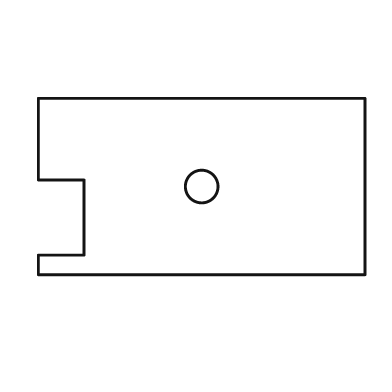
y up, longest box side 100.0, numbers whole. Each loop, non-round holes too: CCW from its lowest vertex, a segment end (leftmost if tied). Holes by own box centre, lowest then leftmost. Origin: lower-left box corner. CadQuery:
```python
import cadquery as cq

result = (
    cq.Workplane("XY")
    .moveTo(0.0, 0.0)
    .lineTo(100.0, 0.0)
    .lineTo(100.0, 54.0)
    .lineTo(0.0, 54.0)
    .lineTo(0.0, 29.0)
    .lineTo(14.0, 29.0)
    .lineTo(14.0, 6.0)
    .lineTo(0.0, 6.0)
    .close()
    .moveTo(50.0, 27.0)
    .circle(5.0)
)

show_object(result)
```